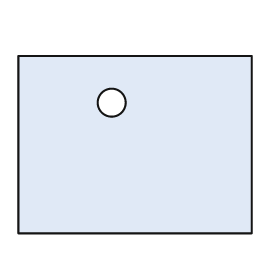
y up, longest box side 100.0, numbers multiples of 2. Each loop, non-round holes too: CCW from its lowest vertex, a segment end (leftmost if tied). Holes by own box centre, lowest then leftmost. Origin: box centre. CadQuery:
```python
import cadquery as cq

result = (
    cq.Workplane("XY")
    .moveTo(-50.0, -38.0)
    .lineTo(50.0, -38.0)
    .lineTo(50.0, 38.0)
    .lineTo(-50.0, 38.0)
    .close()
    .moveTo(-10.0, 18.0)
    .circle(6.0)
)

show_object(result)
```